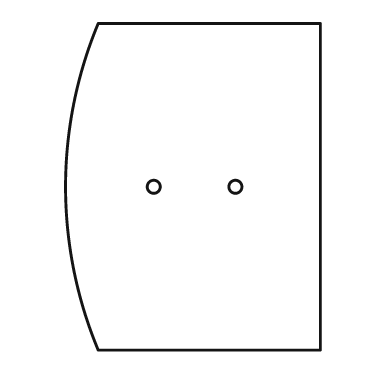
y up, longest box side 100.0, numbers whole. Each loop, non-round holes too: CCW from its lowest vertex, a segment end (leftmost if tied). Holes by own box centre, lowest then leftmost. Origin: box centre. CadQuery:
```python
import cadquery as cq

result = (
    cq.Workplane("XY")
    .moveTo(-29.0, -50.0)
    .lineTo(39.0, -50.0)
    .lineTo(39.0, 50.0)
    .lineTo(-29.0, 50.0)
    .threePointArc((-39.0, 0.0), (-29.0, -50.0))
    .close()
    .moveTo(-12.0, 0.0)
    .circle(2.0)
    .moveTo(13.0, 0.0)
    .circle(2.0)
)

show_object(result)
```